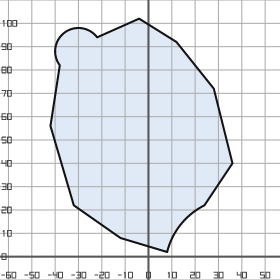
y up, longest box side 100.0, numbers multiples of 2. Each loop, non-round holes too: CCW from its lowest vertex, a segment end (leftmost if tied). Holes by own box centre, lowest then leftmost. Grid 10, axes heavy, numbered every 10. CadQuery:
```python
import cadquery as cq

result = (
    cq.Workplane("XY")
    .moveTo(8.0, 2.0)
    .threePointArc((14.0, 14.0), (24.0, 22.0))
    .lineTo(36.0, 40.0)
    .lineTo(28.0, 72.0)
    .lineTo(12.0, 92.0)
    .lineTo(-4.0, 102.0)
    .lineTo(-22.0, 94.0)
    .threePointArc((-36.0, 96.0), (-38.0, 82.0))
    .lineTo(-42.0, 56.0)
    .lineTo(-32.0, 22.0)
    .lineTo(-12.0, 8.0)
    .close()
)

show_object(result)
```